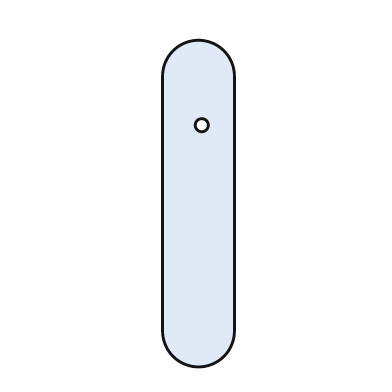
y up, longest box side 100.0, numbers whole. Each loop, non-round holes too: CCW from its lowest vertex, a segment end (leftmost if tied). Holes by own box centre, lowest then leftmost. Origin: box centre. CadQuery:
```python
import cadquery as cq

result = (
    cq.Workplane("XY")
    .moveTo(-11.0, -39.0)
    .threePointArc((0.0, -50.0), (11.0, -39.0))
    .lineTo(11.0, 39.0)
    .threePointArc((0.0, 50.0), (-11.0, 39.0))
    .close()
    .moveTo(1.0, 24.0)
    .circle(2.0)
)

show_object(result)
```